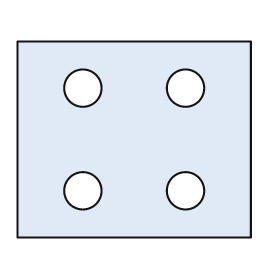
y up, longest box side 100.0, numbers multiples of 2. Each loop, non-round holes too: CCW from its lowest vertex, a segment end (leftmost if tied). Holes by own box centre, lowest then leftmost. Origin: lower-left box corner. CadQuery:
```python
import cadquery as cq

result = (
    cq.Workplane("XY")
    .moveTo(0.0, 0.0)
    .lineTo(100.0, 0.0)
    .lineTo(100.0, 84.0)
    .lineTo(0.0, 84.0)
    .close()
    .moveTo(28.0, 20.0)
    .circle(8.0)
    .moveTo(72.0, 20.0)
    .circle(8.0)
    .moveTo(28.0, 64.0)
    .circle(8.0)
    .moveTo(72.0, 64.0)
    .circle(8.0)
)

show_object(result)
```